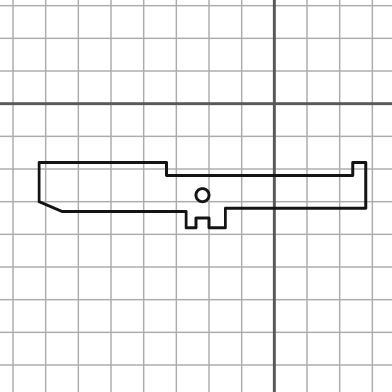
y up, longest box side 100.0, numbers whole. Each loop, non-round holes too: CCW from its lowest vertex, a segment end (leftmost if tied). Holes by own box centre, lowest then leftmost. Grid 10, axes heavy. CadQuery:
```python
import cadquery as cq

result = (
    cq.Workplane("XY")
    .moveTo(-27.0, -38.0)
    .lineTo(-24.0, -38.0)
    .lineTo(-24.0, -35.0)
    .lineTo(-20.0, -35.0)
    .lineTo(-20.0, -38.0)
    .lineTo(-15.0, -38.0)
    .lineTo(-15.0, -32.0)
    .lineTo(28.0, -32.0)
    .lineTo(28.0, -18.0)
    .lineTo(24.0, -18.0)
    .lineTo(24.0, -22.0)
    .lineTo(-33.0, -22.0)
    .lineTo(-33.0, -18.0)
    .lineTo(-72.0, -18.0)
    .lineTo(-72.0, -30.0)
    .lineTo(-65.0, -33.0)
    .lineTo(-27.0, -33.0)
    .close()
    .moveTo(-22.0, -28.0)
    .circle(2.0)
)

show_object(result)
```